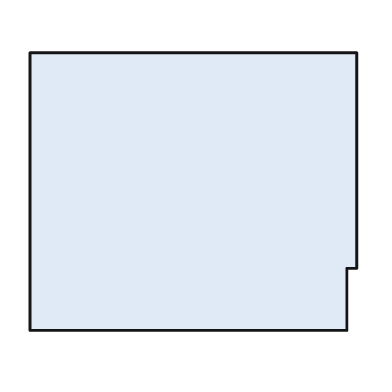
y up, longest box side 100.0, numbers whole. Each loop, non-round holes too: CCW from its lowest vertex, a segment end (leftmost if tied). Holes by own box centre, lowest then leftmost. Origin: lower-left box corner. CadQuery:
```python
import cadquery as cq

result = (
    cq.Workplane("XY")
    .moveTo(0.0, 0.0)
    .lineTo(97.0, 0.0)
    .lineTo(97.0, 19.0)
    .lineTo(100.0, 19.0)
    .lineTo(100.0, 85.0)
    .lineTo(0.0, 85.0)
    .close()
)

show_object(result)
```